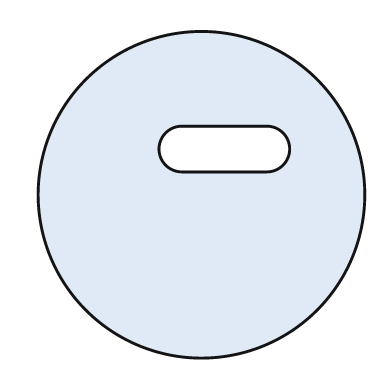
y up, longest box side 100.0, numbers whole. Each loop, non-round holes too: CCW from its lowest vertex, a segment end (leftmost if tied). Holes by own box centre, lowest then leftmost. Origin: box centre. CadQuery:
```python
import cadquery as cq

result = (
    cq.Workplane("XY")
    .moveTo(0.0, 0.0)
    .circle(50.0)
    .moveTo(-6.0, 7.0)
    .lineTo(20.0, 7.0)
    .threePointArc((27.0, 14.0), (20.0, 21.0))
    .lineTo(-6.0, 21.0)
    .threePointArc((-13.0, 14.0), (-6.0, 7.0))
    .close()
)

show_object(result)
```